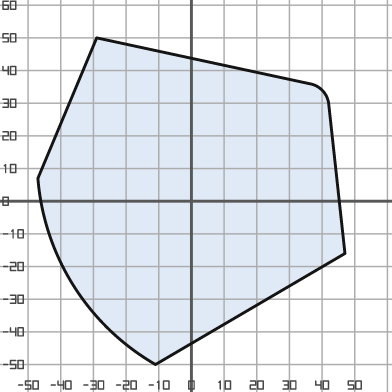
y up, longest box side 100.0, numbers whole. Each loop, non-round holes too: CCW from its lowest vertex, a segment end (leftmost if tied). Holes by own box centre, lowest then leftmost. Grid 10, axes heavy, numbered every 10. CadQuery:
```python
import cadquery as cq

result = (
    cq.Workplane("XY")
    .moveTo(-11.0, -50.0)
    .lineTo(47.0, -16.0)
    .lineTo(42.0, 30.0)
    .threePointArc((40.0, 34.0), (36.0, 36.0))
    .lineTo(-29.0, 50.0)
    .lineTo(-47.0, 7.0)
    .threePointArc((-36.0, -26.0), (-11.0, -50.0))
    .close()
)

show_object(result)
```